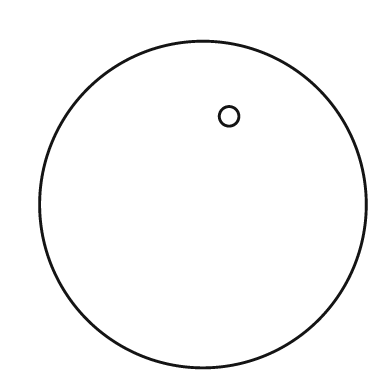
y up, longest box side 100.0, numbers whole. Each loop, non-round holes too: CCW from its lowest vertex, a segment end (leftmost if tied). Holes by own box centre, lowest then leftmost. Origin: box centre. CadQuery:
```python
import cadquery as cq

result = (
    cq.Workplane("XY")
    .moveTo(0.0, 0.0)
    .circle(50.0)
    .moveTo(8.0, 27.0)
    .circle(3.0)
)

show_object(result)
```